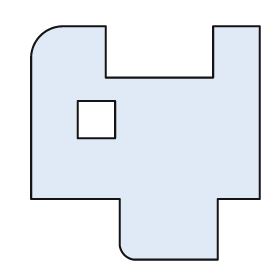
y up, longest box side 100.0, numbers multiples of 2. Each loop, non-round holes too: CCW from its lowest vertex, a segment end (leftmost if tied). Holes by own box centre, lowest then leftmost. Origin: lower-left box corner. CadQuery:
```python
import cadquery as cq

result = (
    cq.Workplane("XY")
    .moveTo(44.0, 0.0)
    .lineTo(80.0, 0.0)
    .lineTo(80.0, 26.0)
    .lineTo(98.0, 26.0)
    .lineTo(98.0, 100.0)
    .lineTo(78.0, 100.0)
    .lineTo(78.0, 78.0)
    .lineTo(32.0, 78.0)
    .lineTo(32.0, 100.0)
    .lineTo(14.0, 100.0)
    .threePointArc((4.0, 96.0), (0.0, 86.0))
    .lineTo(0.0, 26.0)
    .lineTo(38.0, 26.0)
    .lineTo(38.0, 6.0)
    .threePointArc((40.0, 2.0), (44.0, 0.0))
    .close()
    .moveTo(20.0, 52.0)
    .lineTo(36.0, 52.0)
    .lineTo(36.0, 68.0)
    .lineTo(20.0, 68.0)
    .close()
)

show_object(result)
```